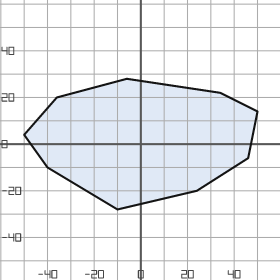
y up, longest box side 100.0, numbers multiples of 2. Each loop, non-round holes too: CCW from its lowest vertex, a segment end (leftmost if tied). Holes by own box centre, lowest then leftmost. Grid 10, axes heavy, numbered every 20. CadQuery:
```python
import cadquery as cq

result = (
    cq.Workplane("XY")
    .moveTo(-10.0, -28.0)
    .lineTo(24.0, -20.0)
    .lineTo(46.0, -6.0)
    .lineTo(50.0, 14.0)
    .lineTo(34.0, 22.0)
    .lineTo(-6.0, 28.0)
    .lineTo(-36.0, 20.0)
    .lineTo(-50.0, 4.0)
    .lineTo(-40.0, -10.0)
    .close()
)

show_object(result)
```